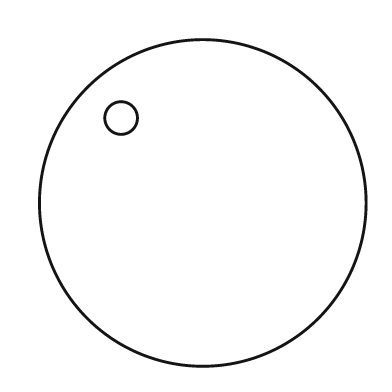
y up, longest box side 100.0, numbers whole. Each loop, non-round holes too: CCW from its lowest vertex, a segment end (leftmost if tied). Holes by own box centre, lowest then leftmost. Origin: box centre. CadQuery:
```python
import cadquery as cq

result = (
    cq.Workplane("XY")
    .moveTo(0.0, 0.0)
    .circle(50.0)
    .moveTo(-25.0, 26.0)
    .circle(5.0)
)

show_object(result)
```